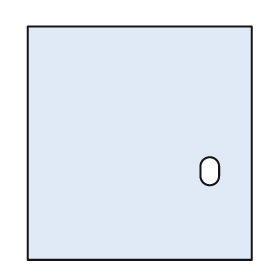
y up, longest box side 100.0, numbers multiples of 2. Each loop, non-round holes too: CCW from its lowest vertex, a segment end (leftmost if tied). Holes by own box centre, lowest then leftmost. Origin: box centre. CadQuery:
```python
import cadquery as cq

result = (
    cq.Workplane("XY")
    .moveTo(-48.0, -50.0)
    .lineTo(48.0, -50.0)
    .lineTo(48.0, 50.0)
    .lineTo(-48.0, 50.0)
    .close()
    .moveTo(26.0, -14.0)
    .threePointArc((30.0, -18.0), (34.0, -14.0))
    .lineTo(34.0, -10.0)
    .threePointArc((30.0, -6.0), (26.0, -10.0))
    .close()
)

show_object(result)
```